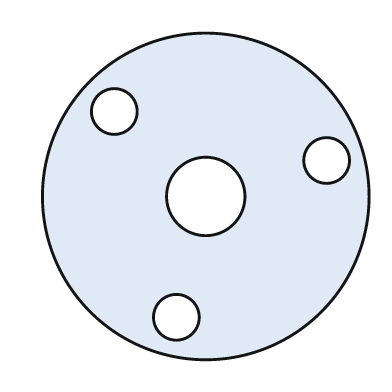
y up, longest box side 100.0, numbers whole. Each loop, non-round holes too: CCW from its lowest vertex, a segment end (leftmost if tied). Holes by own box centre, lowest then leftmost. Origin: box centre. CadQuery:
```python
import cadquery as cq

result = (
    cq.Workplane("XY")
    .moveTo(0.0, 0.0)
    .circle(50.0)
    .moveTo(-9.0, -37.0)
    .circle(7.0)
    .moveTo(0.0, 0.0)
    .circle(12.0)
    .moveTo(37.0, 11.0)
    .circle(7.0)
    .moveTo(-28.0, 26.0)
    .circle(7.0)
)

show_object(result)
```